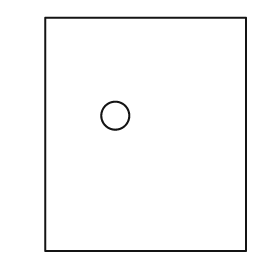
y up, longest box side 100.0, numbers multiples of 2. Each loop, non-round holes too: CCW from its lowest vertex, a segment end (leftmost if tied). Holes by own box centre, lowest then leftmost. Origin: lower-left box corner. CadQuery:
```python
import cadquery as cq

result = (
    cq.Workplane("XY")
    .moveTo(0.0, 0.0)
    .lineTo(86.0, 0.0)
    .lineTo(86.0, 100.0)
    .lineTo(0.0, 100.0)
    .close()
    .moveTo(30.0, 58.0)
    .circle(6.0)
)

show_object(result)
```